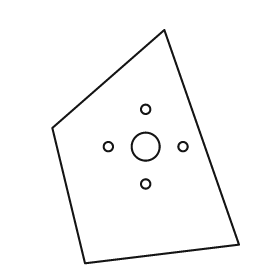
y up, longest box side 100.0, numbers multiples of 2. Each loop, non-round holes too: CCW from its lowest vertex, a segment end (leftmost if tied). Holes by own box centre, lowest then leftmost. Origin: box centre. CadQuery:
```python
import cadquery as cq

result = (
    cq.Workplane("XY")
    .moveTo(-26.0, -50.0)
    .lineTo(40.0, -42.0)
    .lineTo(8.0, 50.0)
    .lineTo(-40.0, 8.0)
    .close()
    .moveTo(0.0, -16.0)
    .circle(2.0)
    .moveTo(-16.0, 0.0)
    .circle(2.0)
    .moveTo(0.0, 0.0)
    .circle(6.0)
    .moveTo(16.0, 0.0)
    .circle(2.0)
    .moveTo(0.0, 16.0)
    .circle(2.0)
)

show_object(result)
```